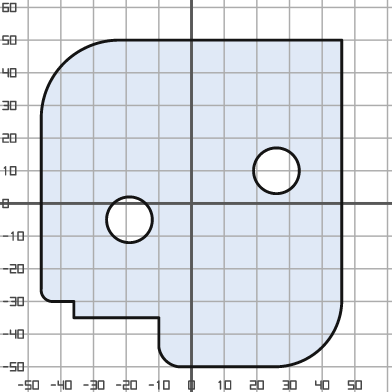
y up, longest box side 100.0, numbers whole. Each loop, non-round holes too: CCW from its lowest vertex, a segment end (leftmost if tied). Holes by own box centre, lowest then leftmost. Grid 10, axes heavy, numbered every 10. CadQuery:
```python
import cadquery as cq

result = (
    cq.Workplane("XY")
    .moveTo(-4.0, -50.0)
    .lineTo(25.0, -50.0)
    .threePointArc((40.0, -44.0), (46.0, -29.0))
    .lineTo(46.0, 50.0)
    .lineTo(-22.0, 50.0)
    .threePointArc((-39.0, 43.0), (-46.0, 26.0))
    .lineTo(-46.0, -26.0)
    .threePointArc((-45.0, -29.0), (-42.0, -30.0))
    .lineTo(-36.0, -30.0)
    .lineTo(-36.0, -35.0)
    .lineTo(-10.0, -35.0)
    .lineTo(-10.0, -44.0)
    .threePointArc((-8.0, -48.0), (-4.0, -50.0))
    .close()
    .moveTo(-19.0, -5.0)
    .circle(7.0)
    .moveTo(26.0, 10.0)
    .circle(7.0)
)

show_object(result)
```